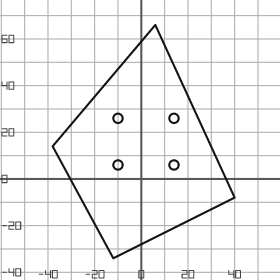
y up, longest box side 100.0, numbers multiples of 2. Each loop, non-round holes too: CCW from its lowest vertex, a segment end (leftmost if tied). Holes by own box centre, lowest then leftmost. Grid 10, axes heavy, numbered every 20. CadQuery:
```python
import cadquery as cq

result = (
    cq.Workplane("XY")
    .moveTo(-12.0, -34.0)
    .lineTo(40.0, -8.0)
    .lineTo(6.0, 66.0)
    .lineTo(-38.0, 14.0)
    .close()
    .moveTo(-10.0, 6.0)
    .circle(2.0)
    .moveTo(14.0, 6.0)
    .circle(2.0)
    .moveTo(-10.0, 26.0)
    .circle(2.0)
    .moveTo(14.0, 26.0)
    .circle(2.0)
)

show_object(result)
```